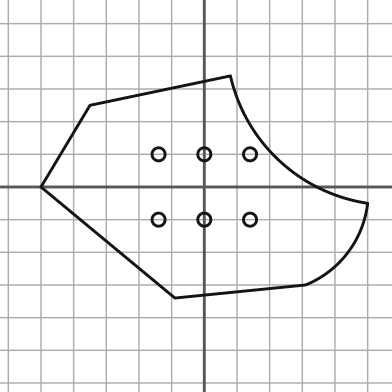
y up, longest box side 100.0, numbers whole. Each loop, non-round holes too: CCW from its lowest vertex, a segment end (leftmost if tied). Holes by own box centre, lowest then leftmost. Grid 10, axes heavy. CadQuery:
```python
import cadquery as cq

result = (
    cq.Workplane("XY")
    .moveTo(-9.0, -34.0)
    .lineTo(31.0, -30.0)
    .threePointArc((44.0, -20.0), (50.0, -5.0))
    .threePointArc((23.0, 8.0), (8.0, 34.0))
    .lineTo(-35.0, 25.0)
    .lineTo(-50.0, 0.0)
    .close()
    .moveTo(-14.0, -10.0)
    .circle(2.0)
    .moveTo(0.0, -10.0)
    .circle(2.0)
    .moveTo(14.0, -10.0)
    .circle(2.0)
    .moveTo(-14.0, 10.0)
    .circle(2.0)
    .moveTo(0.0, 10.0)
    .circle(2.0)
    .moveTo(14.0, 10.0)
    .circle(2.0)
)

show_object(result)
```